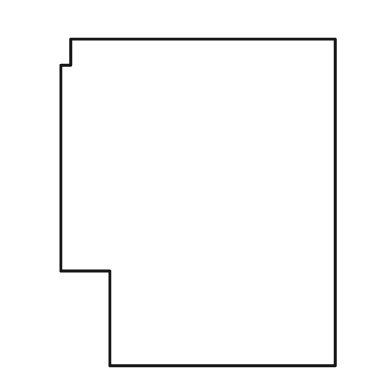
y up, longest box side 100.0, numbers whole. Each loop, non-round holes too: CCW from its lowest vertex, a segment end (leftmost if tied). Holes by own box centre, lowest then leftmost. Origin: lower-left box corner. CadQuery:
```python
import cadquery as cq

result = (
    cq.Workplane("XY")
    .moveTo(15.0, 0.0)
    .lineTo(84.0, 0.0)
    .lineTo(84.0, 100.0)
    .lineTo(3.0, 100.0)
    .lineTo(3.0, 92.0)
    .lineTo(0.0, 92.0)
    .lineTo(0.0, 29.0)
    .lineTo(15.0, 29.0)
    .close()
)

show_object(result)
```